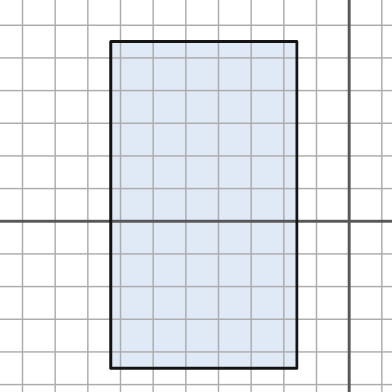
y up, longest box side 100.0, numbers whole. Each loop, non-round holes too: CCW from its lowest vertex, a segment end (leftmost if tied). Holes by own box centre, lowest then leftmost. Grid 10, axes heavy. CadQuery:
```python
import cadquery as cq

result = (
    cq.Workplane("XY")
    .moveTo(-73.0, -45.0)
    .lineTo(-16.0, -45.0)
    .lineTo(-16.0, 55.0)
    .lineTo(-73.0, 55.0)
    .close()
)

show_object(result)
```